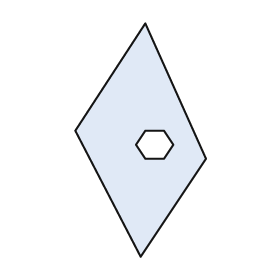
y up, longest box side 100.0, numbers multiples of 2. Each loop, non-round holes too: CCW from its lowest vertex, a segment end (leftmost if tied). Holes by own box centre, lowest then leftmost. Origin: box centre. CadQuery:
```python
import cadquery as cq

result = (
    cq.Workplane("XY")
    .moveTo(0.0, -50.0)
    .lineTo(28.0, -8.0)
    .lineTo(2.0, 50.0)
    .lineTo(-28.0, 4.0)
    .close()
    .moveTo(2.0, -8.0)
    .lineTo(10.0, -8.0)
    .lineTo(14.0, -2.0)
    .lineTo(10.0, 4.0)
    .lineTo(2.0, 4.0)
    .lineTo(-2.0, -2.0)
    .close()
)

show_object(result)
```